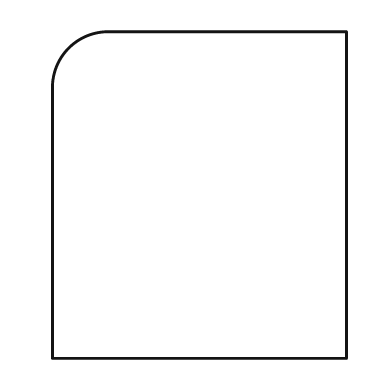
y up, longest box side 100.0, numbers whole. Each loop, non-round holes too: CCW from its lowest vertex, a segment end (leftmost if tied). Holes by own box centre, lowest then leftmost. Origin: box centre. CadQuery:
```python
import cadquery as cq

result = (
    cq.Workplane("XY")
    .moveTo(-45.0, -50.0)
    .lineTo(45.0, -50.0)
    .lineTo(45.0, 50.0)
    .lineTo(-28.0, 50.0)
    .threePointArc((-40.0, 45.0), (-45.0, 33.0))
    .close()
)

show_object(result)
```